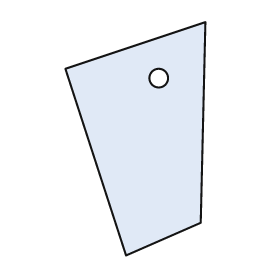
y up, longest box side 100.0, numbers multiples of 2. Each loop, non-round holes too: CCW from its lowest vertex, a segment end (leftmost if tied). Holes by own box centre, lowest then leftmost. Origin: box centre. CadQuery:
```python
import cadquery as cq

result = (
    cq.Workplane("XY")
    .moveTo(-4.0, -50.0)
    .lineTo(28.0, -36.0)
    .lineTo(30.0, 50.0)
    .lineTo(-30.0, 30.0)
    .close()
    .moveTo(10.0, 26.0)
    .circle(4.0)
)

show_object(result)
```